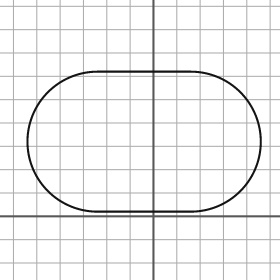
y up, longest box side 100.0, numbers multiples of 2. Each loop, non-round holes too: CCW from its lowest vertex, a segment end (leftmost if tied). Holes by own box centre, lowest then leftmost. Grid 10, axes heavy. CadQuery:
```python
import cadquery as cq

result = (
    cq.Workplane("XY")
    .moveTo(-24.0, 2.0)
    .lineTo(16.0, 2.0)
    .threePointArc((46.0, 32.0), (16.0, 62.0))
    .lineTo(-24.0, 62.0)
    .threePointArc((-54.0, 32.0), (-24.0, 2.0))
    .close()
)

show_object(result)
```